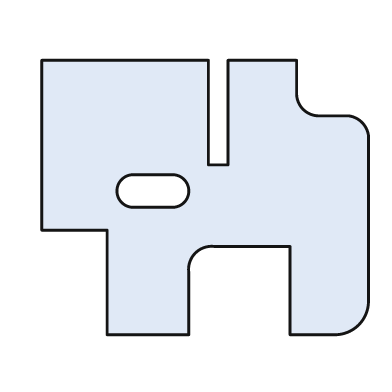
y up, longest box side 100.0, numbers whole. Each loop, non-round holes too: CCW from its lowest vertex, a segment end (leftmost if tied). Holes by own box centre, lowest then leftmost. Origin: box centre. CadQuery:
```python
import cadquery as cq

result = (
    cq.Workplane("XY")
    .moveTo(-30.0, -42.0)
    .lineTo(-5.0, -42.0)
    .lineTo(-5.0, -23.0)
    .threePointArc((-3.0, -17.0), (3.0, -15.0))
    .lineTo(26.0, -15.0)
    .lineTo(26.0, -42.0)
    .lineTo(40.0, -42.0)
    .threePointArc((47.0, -39.0), (50.0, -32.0))
    .lineTo(50.0, 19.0)
    .threePointArc((48.0, 23.0), (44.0, 25.0))
    .lineTo(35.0, 25.0)
    .threePointArc((30.0, 27.0), (28.0, 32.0))
    .lineTo(28.0, 42.0)
    .lineTo(7.0, 42.0)
    .lineTo(7.0, 10.0)
    .lineTo(1.0, 10.0)
    .lineTo(1.0, 42.0)
    .lineTo(-50.0, 42.0)
    .lineTo(-50.0, -10.0)
    .lineTo(-30.0, -10.0)
    .close()
    .moveTo(-22.0, -3.0)
    .lineTo(-10.0, -3.0)
    .threePointArc((-5.0, 2.0), (-10.0, 7.0))
    .lineTo(-22.0, 7.0)
    .threePointArc((-27.0, 2.0), (-22.0, -3.0))
    .close()
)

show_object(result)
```